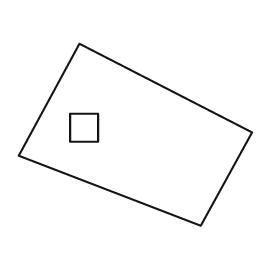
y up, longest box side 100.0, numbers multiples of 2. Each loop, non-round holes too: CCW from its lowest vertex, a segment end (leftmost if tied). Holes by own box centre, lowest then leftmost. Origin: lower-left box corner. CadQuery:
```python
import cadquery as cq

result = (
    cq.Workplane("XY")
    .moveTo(78.0, 0.0)
    .lineTo(100.0, 40.0)
    .lineTo(26.0, 78.0)
    .lineTo(0.0, 30.0)
    .close()
    .moveTo(22.0, 36.0)
    .lineTo(34.0, 36.0)
    .lineTo(34.0, 48.0)
    .lineTo(22.0, 48.0)
    .close()
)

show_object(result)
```